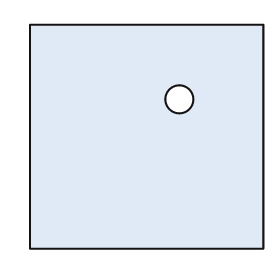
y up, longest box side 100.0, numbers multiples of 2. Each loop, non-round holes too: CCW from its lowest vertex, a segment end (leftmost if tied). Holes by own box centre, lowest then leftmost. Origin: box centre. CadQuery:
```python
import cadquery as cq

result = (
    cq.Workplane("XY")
    .moveTo(-50.0, -48.0)
    .lineTo(50.0, -48.0)
    .lineTo(50.0, 48.0)
    .lineTo(-50.0, 48.0)
    .close()
    .moveTo(14.0, 16.0)
    .circle(6.0)
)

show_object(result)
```